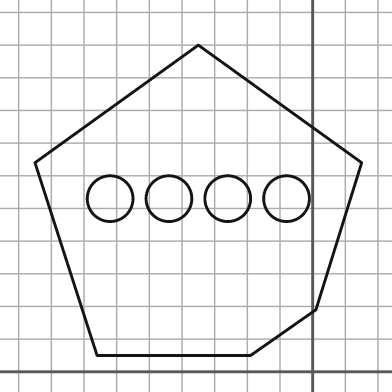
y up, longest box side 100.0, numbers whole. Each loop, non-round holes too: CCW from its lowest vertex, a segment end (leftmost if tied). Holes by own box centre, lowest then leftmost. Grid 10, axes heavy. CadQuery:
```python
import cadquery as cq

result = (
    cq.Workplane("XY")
    .moveTo(-66.0, 5.0)
    .lineTo(-19.0, 5.0)
    .lineTo(1.0, 19.0)
    .lineTo(15.0, 64.0)
    .lineTo(-35.0, 100.0)
    .lineTo(-85.0, 64.0)
    .close()
    .moveTo(-62.0, 53.0)
    .circle(7.0)
    .moveTo(-44.0, 53.0)
    .circle(7.0)
    .moveTo(-26.0, 53.0)
    .circle(7.0)
    .moveTo(-8.0, 53.0)
    .circle(7.0)
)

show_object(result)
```